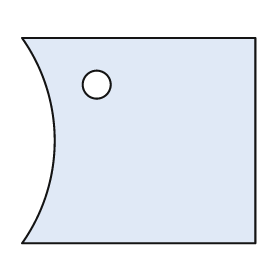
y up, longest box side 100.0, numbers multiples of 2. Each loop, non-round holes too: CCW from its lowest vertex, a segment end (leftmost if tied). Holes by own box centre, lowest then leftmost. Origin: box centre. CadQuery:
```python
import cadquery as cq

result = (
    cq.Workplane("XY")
    .moveTo(-50.0, -44.0)
    .lineTo(50.0, -44.0)
    .lineTo(50.0, 44.0)
    .lineTo(-50.0, 44.0)
    .threePointArc((-36.0, 0.0), (-50.0, -44.0))
    .close()
    .moveTo(-18.0, 24.0)
    .circle(6.0)
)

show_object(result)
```